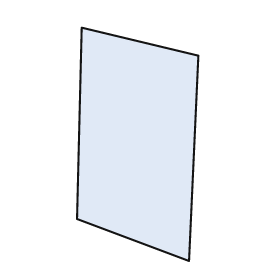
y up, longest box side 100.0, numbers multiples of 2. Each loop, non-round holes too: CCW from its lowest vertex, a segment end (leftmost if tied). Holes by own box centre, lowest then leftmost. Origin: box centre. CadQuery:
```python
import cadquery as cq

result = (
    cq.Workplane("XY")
    .moveTo(22.0, -50.0)
    .lineTo(26.0, 38.0)
    .lineTo(-24.0, 50.0)
    .lineTo(-26.0, -32.0)
    .close()
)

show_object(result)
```